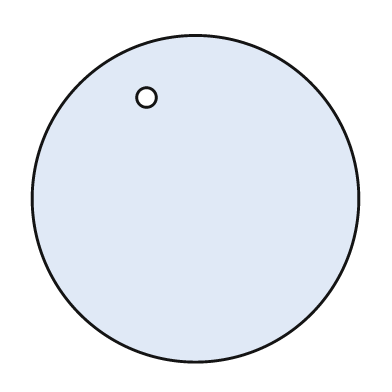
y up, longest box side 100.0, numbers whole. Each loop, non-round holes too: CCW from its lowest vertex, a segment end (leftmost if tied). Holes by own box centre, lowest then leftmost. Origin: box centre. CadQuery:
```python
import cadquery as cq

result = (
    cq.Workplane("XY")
    .moveTo(0.0, 0.0)
    .circle(50.0)
    .moveTo(-15.0, 31.0)
    .circle(3.0)
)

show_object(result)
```